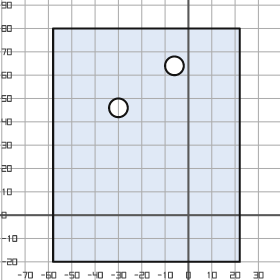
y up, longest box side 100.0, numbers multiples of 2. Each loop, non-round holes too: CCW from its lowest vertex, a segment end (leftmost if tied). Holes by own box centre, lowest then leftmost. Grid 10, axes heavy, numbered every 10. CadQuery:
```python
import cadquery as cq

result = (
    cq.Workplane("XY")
    .moveTo(-58.0, -20.0)
    .lineTo(22.0, -20.0)
    .lineTo(22.0, 80.0)
    .lineTo(-58.0, 80.0)
    .close()
    .moveTo(-30.0, 46.0)
    .circle(4.0)
    .moveTo(-6.0, 64.0)
    .circle(4.0)
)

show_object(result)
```